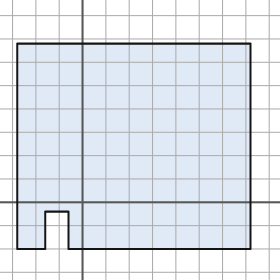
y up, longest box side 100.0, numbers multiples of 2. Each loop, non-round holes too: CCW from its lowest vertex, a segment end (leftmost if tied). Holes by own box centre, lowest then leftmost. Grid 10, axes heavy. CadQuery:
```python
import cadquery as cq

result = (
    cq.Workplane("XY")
    .moveTo(-28.0, -20.0)
    .lineTo(-16.0, -20.0)
    .lineTo(-16.0, -4.0)
    .lineTo(-6.0, -4.0)
    .lineTo(-6.0, -20.0)
    .lineTo(72.0, -20.0)
    .lineTo(72.0, 68.0)
    .lineTo(-28.0, 68.0)
    .close()
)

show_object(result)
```